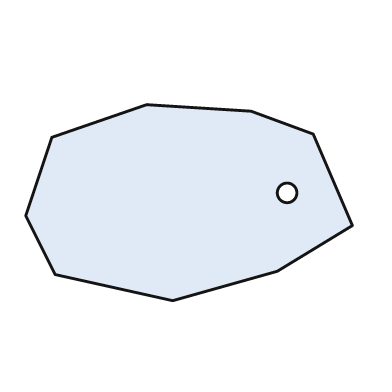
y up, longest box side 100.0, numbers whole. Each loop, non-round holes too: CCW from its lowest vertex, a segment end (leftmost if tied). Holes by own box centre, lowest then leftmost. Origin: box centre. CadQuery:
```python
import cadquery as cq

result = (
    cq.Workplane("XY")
    .moveTo(-5.0, -30.0)
    .lineTo(27.0, -21.0)
    .lineTo(50.0, -7.0)
    .lineTo(38.0, 21.0)
    .lineTo(19.0, 28.0)
    .lineTo(-13.0, 30.0)
    .lineTo(-42.0, 20.0)
    .lineTo(-50.0, -4.0)
    .lineTo(-41.0, -22.0)
    .close()
    .moveTo(30.0, 3.0)
    .circle(3.0)
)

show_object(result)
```